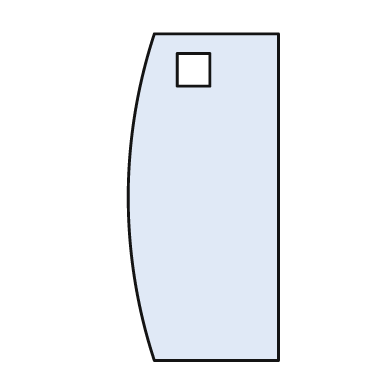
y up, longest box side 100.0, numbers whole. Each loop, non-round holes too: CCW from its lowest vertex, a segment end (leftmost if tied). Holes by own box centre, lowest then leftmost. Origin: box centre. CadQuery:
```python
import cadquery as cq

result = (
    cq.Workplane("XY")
    .moveTo(-15.0, -50.0)
    .lineTo(23.0, -50.0)
    .lineTo(23.0, 50.0)
    .lineTo(-15.0, 50.0)
    .threePointArc((-23.0, 0.0), (-15.0, -50.0))
    .close()
    .moveTo(-8.0, 34.0)
    .lineTo(2.0, 34.0)
    .lineTo(2.0, 44.0)
    .lineTo(-8.0, 44.0)
    .close()
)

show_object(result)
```